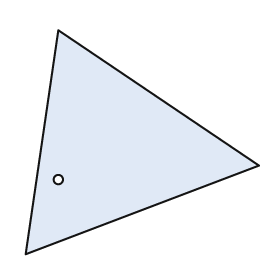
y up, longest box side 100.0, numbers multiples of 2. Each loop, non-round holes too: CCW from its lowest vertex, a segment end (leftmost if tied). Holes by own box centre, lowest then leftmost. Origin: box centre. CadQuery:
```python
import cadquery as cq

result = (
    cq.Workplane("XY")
    .moveTo(-50.0, -48.0)
    .lineTo(50.0, -10.0)
    .lineTo(-36.0, 48.0)
    .close()
    .moveTo(-36.0, -16.0)
    .circle(2.0)
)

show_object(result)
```